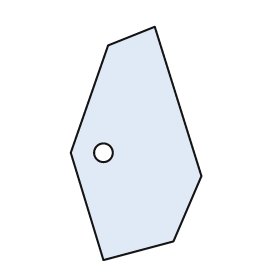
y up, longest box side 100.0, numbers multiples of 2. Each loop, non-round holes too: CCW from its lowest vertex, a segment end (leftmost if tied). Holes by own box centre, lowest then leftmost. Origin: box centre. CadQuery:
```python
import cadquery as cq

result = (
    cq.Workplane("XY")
    .moveTo(-14.0, -50.0)
    .lineTo(16.0, -42.0)
    .lineTo(28.0, -14.0)
    .lineTo(8.0, 50.0)
    .lineTo(-12.0, 42.0)
    .lineTo(-28.0, -4.0)
    .close()
    .moveTo(-14.0, -4.0)
    .circle(4.0)
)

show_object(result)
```